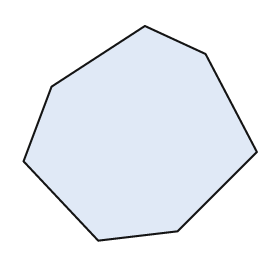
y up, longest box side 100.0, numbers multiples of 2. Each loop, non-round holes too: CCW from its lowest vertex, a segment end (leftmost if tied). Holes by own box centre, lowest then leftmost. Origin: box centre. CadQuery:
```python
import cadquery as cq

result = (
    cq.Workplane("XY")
    .moveTo(-18.0, -46.0)
    .lineTo(16.0, -42.0)
    .lineTo(50.0, -8.0)
    .lineTo(28.0, 34.0)
    .lineTo(2.0, 46.0)
    .lineTo(-38.0, 20.0)
    .lineTo(-50.0, -12.0)
    .close()
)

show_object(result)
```